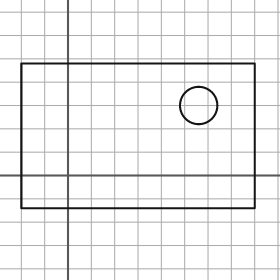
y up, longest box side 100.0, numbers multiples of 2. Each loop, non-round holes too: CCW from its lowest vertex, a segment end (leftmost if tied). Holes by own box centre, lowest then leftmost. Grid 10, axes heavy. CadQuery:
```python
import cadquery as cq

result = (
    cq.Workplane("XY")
    .moveTo(-20.0, -14.0)
    .lineTo(80.0, -14.0)
    .lineTo(80.0, 48.0)
    .lineTo(-20.0, 48.0)
    .close()
    .moveTo(56.0, 30.0)
    .circle(8.0)
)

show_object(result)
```